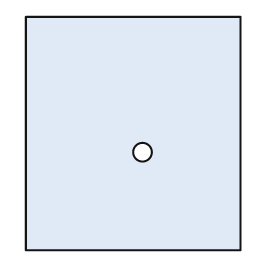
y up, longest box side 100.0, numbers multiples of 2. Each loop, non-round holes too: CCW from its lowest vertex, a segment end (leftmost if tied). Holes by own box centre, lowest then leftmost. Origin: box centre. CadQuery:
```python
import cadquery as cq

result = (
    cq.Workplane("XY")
    .moveTo(-46.0, -50.0)
    .lineTo(46.0, -50.0)
    .lineTo(46.0, 50.0)
    .lineTo(-46.0, 50.0)
    .close()
    .moveTo(4.0, -8.0)
    .circle(4.0)
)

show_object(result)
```